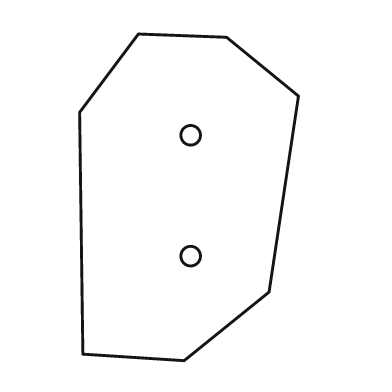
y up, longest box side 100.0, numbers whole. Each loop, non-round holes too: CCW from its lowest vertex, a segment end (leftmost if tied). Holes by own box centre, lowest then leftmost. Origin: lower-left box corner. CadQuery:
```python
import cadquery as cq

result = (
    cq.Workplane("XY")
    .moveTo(32.0, 0.0)
    .lineTo(58.0, 21.0)
    .lineTo(67.0, 81.0)
    .lineTo(45.0, 99.0)
    .lineTo(18.0, 100.0)
    .lineTo(0.0, 76.0)
    .lineTo(1.0, 2.0)
    .close()
    .moveTo(34.0, 32.0)
    .circle(3.0)
    .moveTo(34.0, 69.0)
    .circle(3.0)
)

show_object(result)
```